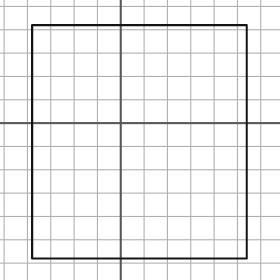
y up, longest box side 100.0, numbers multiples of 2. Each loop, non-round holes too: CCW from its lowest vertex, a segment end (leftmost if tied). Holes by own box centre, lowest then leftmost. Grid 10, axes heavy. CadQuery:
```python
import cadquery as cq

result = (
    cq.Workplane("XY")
    .moveTo(-38.0, -58.0)
    .lineTo(54.0, -58.0)
    .lineTo(54.0, 42.0)
    .lineTo(-38.0, 42.0)
    .close()
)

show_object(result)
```